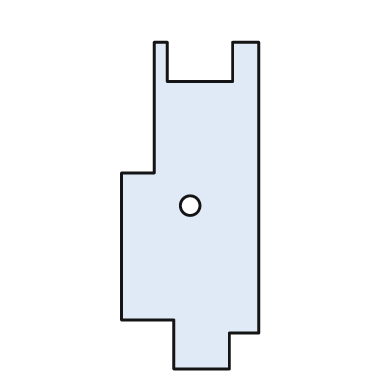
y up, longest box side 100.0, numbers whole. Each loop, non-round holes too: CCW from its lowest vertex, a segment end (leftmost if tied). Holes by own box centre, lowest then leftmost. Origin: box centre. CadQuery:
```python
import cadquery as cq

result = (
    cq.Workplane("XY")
    .moveTo(-5.0, -50.0)
    .lineTo(12.0, -50.0)
    .lineTo(12.0, -39.0)
    .lineTo(21.0, -39.0)
    .lineTo(21.0, 50.0)
    .lineTo(13.0, 50.0)
    .lineTo(13.0, 38.0)
    .lineTo(-7.0, 38.0)
    .lineTo(-7.0, 50.0)
    .lineTo(-11.0, 50.0)
    .lineTo(-11.0, 10.0)
    .lineTo(-21.0, 10.0)
    .lineTo(-21.0, -35.0)
    .lineTo(-5.0, -35.0)
    .close()
    .moveTo(0.0, 0.0)
    .circle(3.0)
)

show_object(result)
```